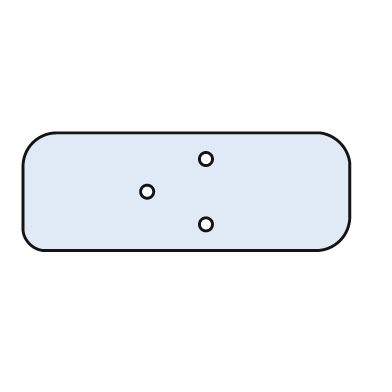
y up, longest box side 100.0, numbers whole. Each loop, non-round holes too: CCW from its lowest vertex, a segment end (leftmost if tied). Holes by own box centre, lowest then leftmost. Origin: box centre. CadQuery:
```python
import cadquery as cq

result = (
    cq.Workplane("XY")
    .moveTo(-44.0, -18.0)
    .lineTo(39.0, -18.0)
    .threePointArc((47.0, -15.0), (50.0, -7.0))
    .lineTo(50.0, 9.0)
    .threePointArc((47.0, 15.0), (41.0, 18.0))
    .lineTo(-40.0, 18.0)
    .threePointArc((-47.0, 15.0), (-50.0, 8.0))
    .lineTo(-50.0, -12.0)
    .threePointArc((-48.0, -16.0), (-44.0, -18.0))
    .close()
    .moveTo(6.0, -10.0)
    .circle(2.0)
    .moveTo(-12.0, 0.0)
    .circle(2.0)
    .moveTo(6.0, 10.0)
    .circle(2.0)
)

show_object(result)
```